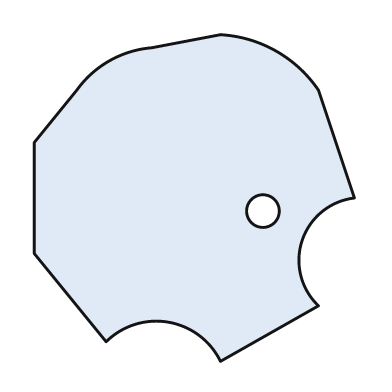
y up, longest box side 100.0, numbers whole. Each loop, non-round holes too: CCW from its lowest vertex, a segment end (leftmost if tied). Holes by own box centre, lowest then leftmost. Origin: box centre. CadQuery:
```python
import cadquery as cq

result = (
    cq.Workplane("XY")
    .moveTo(8.0, -50.0)
    .lineTo(38.0, -33.0)
    .threePointArc((33.0, -13.0), (49.0, 0.0))
    .lineTo(38.0, 33.0)
    .threePointArc((25.0, 45.0), (8.0, 50.0))
    .lineTo(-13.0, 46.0)
    .threePointArc((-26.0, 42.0), (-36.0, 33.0))
    .lineTo(-49.0, 17.0)
    .lineTo(-49.0, -17.0)
    .lineTo(-27.0, -44.0)
    .threePointArc((-8.0, -38.0), (8.0, -50.0))
    .close()
    .moveTo(21.0, -4.0)
    .circle(5.0)
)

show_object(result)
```